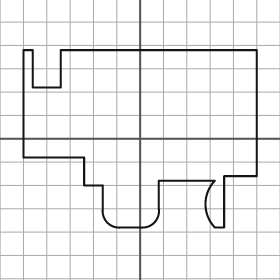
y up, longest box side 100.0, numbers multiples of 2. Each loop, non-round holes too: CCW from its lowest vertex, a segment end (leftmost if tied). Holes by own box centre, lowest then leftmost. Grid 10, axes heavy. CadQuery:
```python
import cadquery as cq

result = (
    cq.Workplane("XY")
    .moveTo(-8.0, -38.0)
    .lineTo(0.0, -38.0)
    .threePointArc((6.0, -36.0), (8.0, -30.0))
    .lineTo(8.0, -18.0)
    .lineTo(32.0, -18.0)
    .threePointArc((28.0, -28.0), (32.0, -38.0))
    .lineTo(36.0, -38.0)
    .lineTo(36.0, -16.0)
    .lineTo(50.0, -16.0)
    .lineTo(50.0, 38.0)
    .lineTo(-34.0, 38.0)
    .lineTo(-34.0, 22.0)
    .lineTo(-46.0, 22.0)
    .lineTo(-46.0, 38.0)
    .lineTo(-50.0, 38.0)
    .lineTo(-50.0, -8.0)
    .lineTo(-24.0, -8.0)
    .lineTo(-24.0, -20.0)
    .lineTo(-16.0, -20.0)
    .lineTo(-16.0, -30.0)
    .threePointArc((-14.0, -36.0), (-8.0, -38.0))
    .close()
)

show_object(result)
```